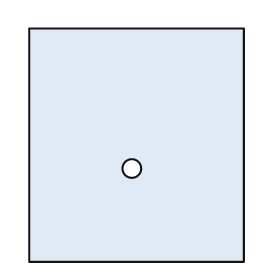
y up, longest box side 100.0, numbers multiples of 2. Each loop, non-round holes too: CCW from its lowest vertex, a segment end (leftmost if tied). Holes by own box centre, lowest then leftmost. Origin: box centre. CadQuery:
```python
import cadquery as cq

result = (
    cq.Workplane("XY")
    .moveTo(-46.0, -50.0)
    .lineTo(46.0, -50.0)
    .lineTo(46.0, 50.0)
    .lineTo(-46.0, 50.0)
    .close()
    .moveTo(-2.0, -10.0)
    .circle(4.0)
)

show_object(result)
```